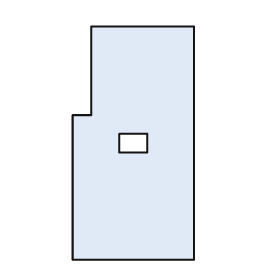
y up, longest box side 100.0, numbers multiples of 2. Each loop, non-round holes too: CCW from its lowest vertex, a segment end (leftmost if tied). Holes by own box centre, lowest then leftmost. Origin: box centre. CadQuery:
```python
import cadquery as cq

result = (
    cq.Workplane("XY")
    .moveTo(-26.0, -50.0)
    .lineTo(26.0, -50.0)
    .lineTo(26.0, 50.0)
    .lineTo(-18.0, 50.0)
    .lineTo(-18.0, 12.0)
    .lineTo(-26.0, 12.0)
    .close()
    .moveTo(-6.0, -4.0)
    .lineTo(6.0, -4.0)
    .lineTo(6.0, 4.0)
    .lineTo(-6.0, 4.0)
    .close()
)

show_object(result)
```